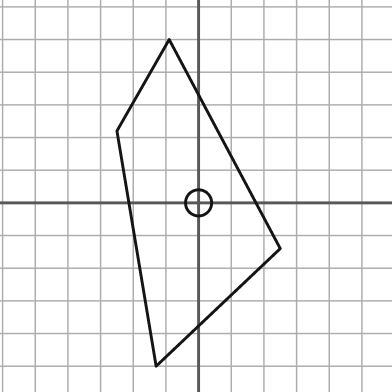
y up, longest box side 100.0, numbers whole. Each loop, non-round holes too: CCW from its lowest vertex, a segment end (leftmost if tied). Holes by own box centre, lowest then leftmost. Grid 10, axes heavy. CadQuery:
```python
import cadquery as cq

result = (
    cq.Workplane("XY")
    .moveTo(-13.0, -50.0)
    .lineTo(25.0, -14.0)
    .lineTo(-9.0, 50.0)
    .lineTo(-25.0, 22.0)
    .close()
    .moveTo(0.0, 0.0)
    .circle(4.0)
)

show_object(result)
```